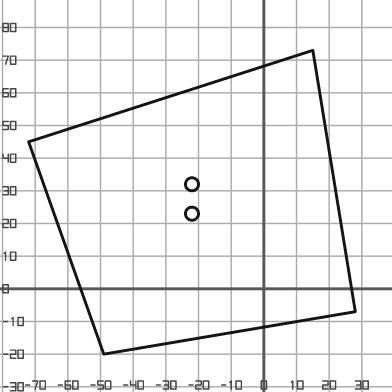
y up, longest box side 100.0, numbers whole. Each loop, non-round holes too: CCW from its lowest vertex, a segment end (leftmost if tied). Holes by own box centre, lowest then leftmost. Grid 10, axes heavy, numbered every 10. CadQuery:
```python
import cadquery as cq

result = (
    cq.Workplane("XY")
    .moveTo(-49.0, -20.0)
    .lineTo(28.0, -7.0)
    .lineTo(15.0, 73.0)
    .lineTo(-72.0, 45.0)
    .close()
    .moveTo(-22.0, 23.0)
    .circle(2.0)
    .moveTo(-22.0, 32.0)
    .circle(2.0)
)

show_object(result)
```